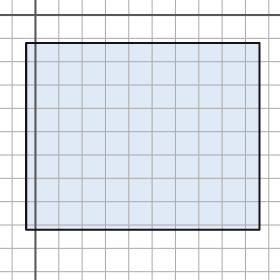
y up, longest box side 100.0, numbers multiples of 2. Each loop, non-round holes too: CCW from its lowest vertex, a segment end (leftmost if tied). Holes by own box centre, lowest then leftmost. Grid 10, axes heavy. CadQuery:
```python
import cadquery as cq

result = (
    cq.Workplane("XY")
    .moveTo(-4.0, -92.0)
    .lineTo(96.0, -92.0)
    .lineTo(96.0, -12.0)
    .lineTo(-4.0, -12.0)
    .close()
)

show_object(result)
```